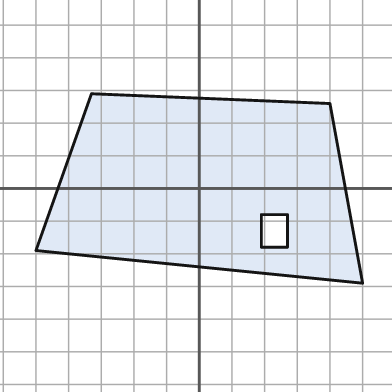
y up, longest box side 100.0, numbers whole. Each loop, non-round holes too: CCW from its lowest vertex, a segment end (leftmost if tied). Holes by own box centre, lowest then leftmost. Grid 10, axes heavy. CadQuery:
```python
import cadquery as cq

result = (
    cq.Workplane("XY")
    .moveTo(50.0, -29.0)
    .lineTo(40.0, 26.0)
    .lineTo(-33.0, 29.0)
    .lineTo(-50.0, -19.0)
    .close()
    .moveTo(19.0, -18.0)
    .lineTo(27.0, -18.0)
    .lineTo(27.0, -8.0)
    .lineTo(19.0, -8.0)
    .close()
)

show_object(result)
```